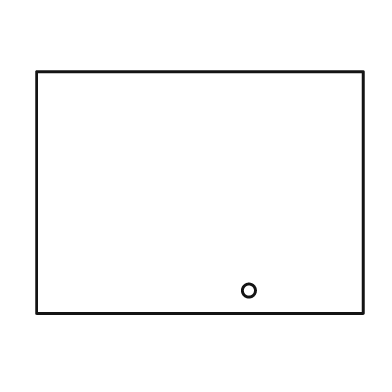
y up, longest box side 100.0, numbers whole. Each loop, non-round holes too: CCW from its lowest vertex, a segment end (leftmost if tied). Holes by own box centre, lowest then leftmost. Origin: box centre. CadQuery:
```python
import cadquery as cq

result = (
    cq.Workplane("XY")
    .moveTo(-50.0, -37.0)
    .lineTo(50.0, -37.0)
    .lineTo(50.0, 37.0)
    .lineTo(-50.0, 37.0)
    .close()
    .moveTo(15.0, -30.0)
    .circle(2.0)
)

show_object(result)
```